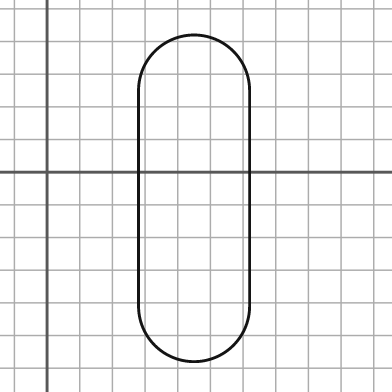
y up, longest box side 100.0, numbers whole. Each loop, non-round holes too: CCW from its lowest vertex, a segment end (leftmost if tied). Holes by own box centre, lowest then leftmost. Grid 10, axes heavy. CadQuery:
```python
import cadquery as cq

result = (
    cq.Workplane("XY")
    .moveTo(28.0, -41.0)
    .threePointArc((45.0, -58.0), (62.0, -41.0))
    .lineTo(62.0, 25.0)
    .threePointArc((45.0, 42.0), (28.0, 25.0))
    .close()
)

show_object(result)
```